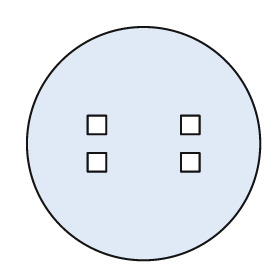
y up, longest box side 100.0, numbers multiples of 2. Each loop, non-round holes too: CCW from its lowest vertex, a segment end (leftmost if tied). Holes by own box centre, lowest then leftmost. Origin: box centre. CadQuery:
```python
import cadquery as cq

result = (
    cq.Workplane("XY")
    .moveTo(0.0, 0.0)
    .circle(50.0)
    .moveTo(-24.0, -12.0)
    .lineTo(-16.0, -12.0)
    .lineTo(-16.0, -4.0)
    .lineTo(-24.0, -4.0)
    .close()
    .moveTo(16.0, -12.0)
    .lineTo(24.0, -12.0)
    .lineTo(24.0, -4.0)
    .lineTo(16.0, -4.0)
    .close()
    .moveTo(-24.0, 4.0)
    .lineTo(-16.0, 4.0)
    .lineTo(-16.0, 12.0)
    .lineTo(-24.0, 12.0)
    .close()
    .moveTo(16.0, 4.0)
    .lineTo(24.0, 4.0)
    .lineTo(24.0, 12.0)
    .lineTo(16.0, 12.0)
    .close()
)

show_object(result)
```